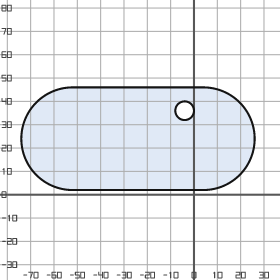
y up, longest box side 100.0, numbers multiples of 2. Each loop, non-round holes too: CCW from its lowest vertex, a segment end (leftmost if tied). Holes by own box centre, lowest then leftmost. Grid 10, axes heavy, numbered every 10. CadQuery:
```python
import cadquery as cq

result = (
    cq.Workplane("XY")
    .moveTo(-52.0, 2.0)
    .lineTo(4.0, 2.0)
    .threePointArc((26.0, 24.0), (4.0, 46.0))
    .lineTo(-52.0, 46.0)
    .threePointArc((-74.0, 24.0), (-52.0, 2.0))
    .close()
    .moveTo(-4.0, 36.0)
    .circle(4.0)
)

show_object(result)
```